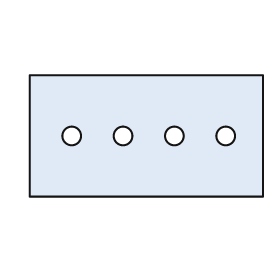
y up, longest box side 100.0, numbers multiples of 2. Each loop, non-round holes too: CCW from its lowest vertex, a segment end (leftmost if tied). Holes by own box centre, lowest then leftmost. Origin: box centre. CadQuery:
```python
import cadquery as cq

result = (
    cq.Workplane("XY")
    .moveTo(-50.0, -26.0)
    .lineTo(50.0, -26.0)
    .lineTo(50.0, 26.0)
    .lineTo(-50.0, 26.0)
    .close()
    .moveTo(-32.0, 0.0)
    .circle(4.0)
    .moveTo(-10.0, 0.0)
    .circle(4.0)
    .moveTo(12.0, 0.0)
    .circle(4.0)
    .moveTo(34.0, 0.0)
    .circle(4.0)
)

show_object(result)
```